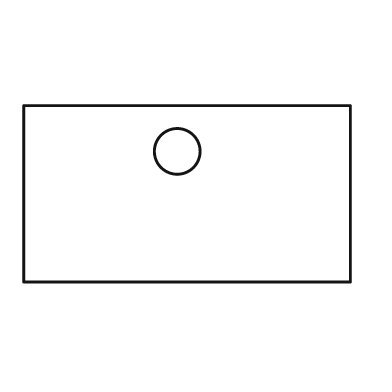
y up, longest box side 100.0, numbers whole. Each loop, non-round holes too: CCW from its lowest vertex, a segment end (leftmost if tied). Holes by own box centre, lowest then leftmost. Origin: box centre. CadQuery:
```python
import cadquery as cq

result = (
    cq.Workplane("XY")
    .moveTo(-50.0, -27.0)
    .lineTo(50.0, -27.0)
    .lineTo(50.0, 27.0)
    .lineTo(-50.0, 27.0)
    .close()
    .moveTo(-3.0, 13.0)
    .circle(7.0)
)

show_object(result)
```